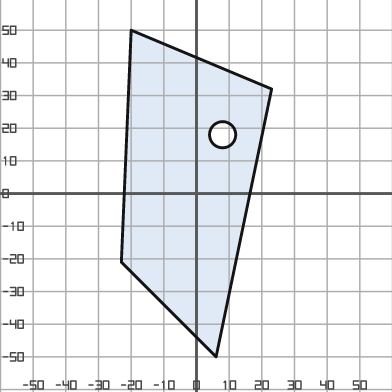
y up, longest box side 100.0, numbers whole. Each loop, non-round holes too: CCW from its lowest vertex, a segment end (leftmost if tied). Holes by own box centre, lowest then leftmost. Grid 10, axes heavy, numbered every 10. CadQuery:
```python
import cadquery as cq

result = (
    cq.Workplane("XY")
    .moveTo(6.0, -50.0)
    .lineTo(23.0, 32.0)
    .lineTo(-20.0, 50.0)
    .lineTo(-23.0, -21.0)
    .close()
    .moveTo(8.0, 18.0)
    .circle(4.0)
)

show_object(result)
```